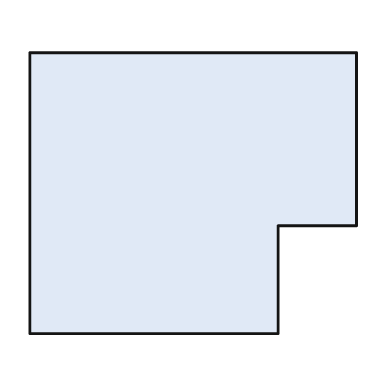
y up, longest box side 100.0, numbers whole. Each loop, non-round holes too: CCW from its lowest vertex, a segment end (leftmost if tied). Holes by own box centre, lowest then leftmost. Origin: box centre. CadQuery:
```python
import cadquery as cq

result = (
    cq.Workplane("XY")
    .moveTo(-50.0, -43.0)
    .lineTo(26.0, -43.0)
    .lineTo(26.0, -10.0)
    .lineTo(50.0, -10.0)
    .lineTo(50.0, 43.0)
    .lineTo(-50.0, 43.0)
    .close()
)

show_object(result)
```